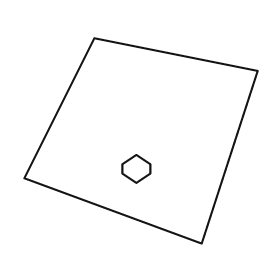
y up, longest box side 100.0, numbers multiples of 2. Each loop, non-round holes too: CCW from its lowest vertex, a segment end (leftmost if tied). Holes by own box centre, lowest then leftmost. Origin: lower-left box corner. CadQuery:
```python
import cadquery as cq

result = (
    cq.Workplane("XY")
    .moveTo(76.0, 0.0)
    .lineTo(100.0, 74.0)
    .lineTo(30.0, 88.0)
    .lineTo(0.0, 28.0)
    .close()
    .moveTo(48.0, 26.0)
    .lineTo(54.0, 30.0)
    .lineTo(54.0, 34.0)
    .lineTo(48.0, 38.0)
    .lineTo(42.0, 34.0)
    .lineTo(42.0, 30.0)
    .close()
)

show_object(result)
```